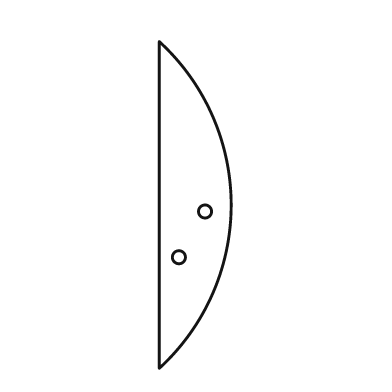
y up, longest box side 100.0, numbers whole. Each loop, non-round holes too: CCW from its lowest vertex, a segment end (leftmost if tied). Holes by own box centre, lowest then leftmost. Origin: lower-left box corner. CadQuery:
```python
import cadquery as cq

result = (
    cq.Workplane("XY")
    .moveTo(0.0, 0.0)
    .threePointArc((22.0, 50.0), (0.0, 100.0))
    .close()
    .moveTo(6.0, 34.0)
    .circle(2.0)
    .moveTo(14.0, 48.0)
    .circle(2.0)
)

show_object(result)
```